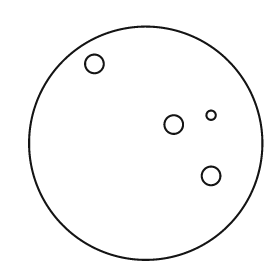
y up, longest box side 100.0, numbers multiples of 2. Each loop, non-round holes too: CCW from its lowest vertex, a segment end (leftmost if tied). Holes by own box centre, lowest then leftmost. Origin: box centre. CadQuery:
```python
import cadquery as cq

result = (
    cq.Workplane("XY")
    .moveTo(0.0, 0.0)
    .circle(50.0)
    .moveTo(28.0, -14.0)
    .circle(4.0)
    .moveTo(12.0, 8.0)
    .circle(4.0)
    .moveTo(28.0, 12.0)
    .circle(2.0)
    .moveTo(-22.0, 34.0)
    .circle(4.0)
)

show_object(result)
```